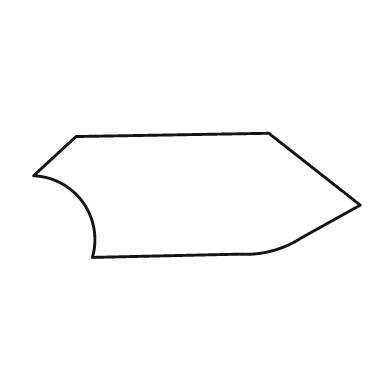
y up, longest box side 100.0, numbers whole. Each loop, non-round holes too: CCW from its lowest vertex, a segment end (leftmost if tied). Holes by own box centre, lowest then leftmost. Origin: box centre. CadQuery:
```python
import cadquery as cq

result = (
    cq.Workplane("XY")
    .moveTo(-32.0, -19.0)
    .lineTo(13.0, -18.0)
    .threePointArc((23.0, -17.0), (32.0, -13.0))
    .lineTo(50.0, -3.0)
    .lineTo(22.0, 19.0)
    .lineTo(-37.0, 18.0)
    .lineTo(-50.0, 6.0)
    .threePointArc((-35.0, -2.0), (-32.0, -19.0))
    .close()
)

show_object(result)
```